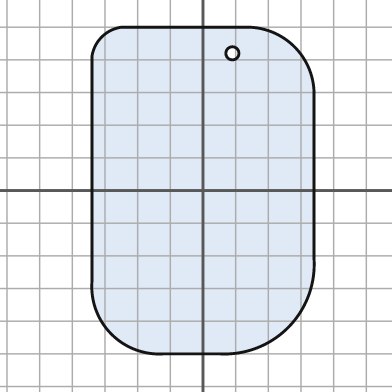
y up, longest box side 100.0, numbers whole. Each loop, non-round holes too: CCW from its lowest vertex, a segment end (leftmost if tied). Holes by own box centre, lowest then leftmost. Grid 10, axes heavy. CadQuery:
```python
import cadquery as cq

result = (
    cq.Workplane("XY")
    .moveTo(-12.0, -50.0)
    .lineTo(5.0, -50.0)
    .threePointArc((26.0, -42.0), (34.0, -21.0))
    .lineTo(34.0, 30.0)
    .threePointArc((28.0, 44.0), (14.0, 50.0))
    .lineTo(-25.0, 50.0)
    .threePointArc((-31.0, 47.0), (-34.0, 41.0))
    .lineTo(-34.0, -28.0)
    .threePointArc((-28.0, -44.0), (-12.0, -50.0))
    .close()
    .moveTo(9.0, 42.0)
    .circle(2.0)
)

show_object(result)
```